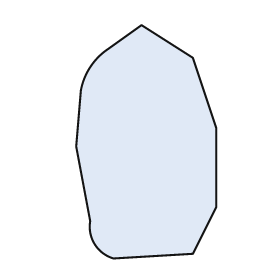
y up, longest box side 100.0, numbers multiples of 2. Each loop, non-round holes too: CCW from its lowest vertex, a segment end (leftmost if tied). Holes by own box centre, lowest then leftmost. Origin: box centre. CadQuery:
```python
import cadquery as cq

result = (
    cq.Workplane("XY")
    .moveTo(-14.0, -50.0)
    .lineTo(20.0, -48.0)
    .lineTo(30.0, -28.0)
    .lineTo(30.0, 6.0)
    .lineTo(20.0, 36.0)
    .lineTo(-2.0, 50.0)
    .lineTo(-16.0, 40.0)
    .threePointArc((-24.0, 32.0), (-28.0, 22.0))
    .lineTo(-30.0, -2.0)
    .lineTo(-24.0, -34.0)
    .threePointArc((-22.0, -44.0), (-14.0, -50.0))
    .close()
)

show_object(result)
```